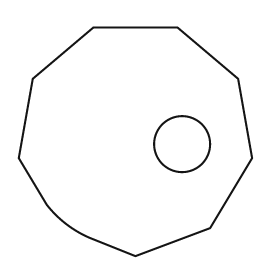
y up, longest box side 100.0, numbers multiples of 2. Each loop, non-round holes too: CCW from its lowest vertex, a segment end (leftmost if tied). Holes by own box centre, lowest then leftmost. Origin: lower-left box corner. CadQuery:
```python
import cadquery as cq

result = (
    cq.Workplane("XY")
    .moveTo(50.0, 0.0)
    .lineTo(82.0, 12.0)
    .lineTo(100.0, 42.0)
    .lineTo(94.0, 76.0)
    .lineTo(68.0, 98.0)
    .lineTo(32.0, 98.0)
    .lineTo(6.0, 76.0)
    .lineTo(0.0, 42.0)
    .lineTo(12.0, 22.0)
    .threePointArc((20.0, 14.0), (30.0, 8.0))
    .close()
    .moveTo(70.0, 48.0)
    .circle(12.0)
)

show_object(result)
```